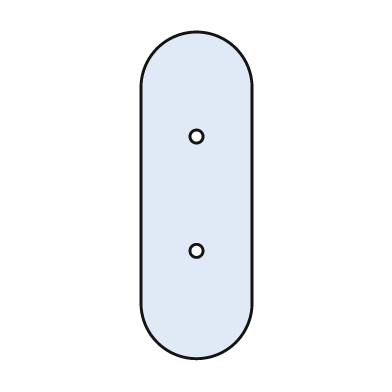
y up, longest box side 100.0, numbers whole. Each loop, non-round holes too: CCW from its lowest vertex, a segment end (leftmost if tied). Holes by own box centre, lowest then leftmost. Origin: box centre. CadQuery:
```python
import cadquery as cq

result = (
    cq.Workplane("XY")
    .moveTo(-17.0, -33.0)
    .threePointArc((0.0, -50.0), (17.0, -33.0))
    .lineTo(17.0, 33.0)
    .threePointArc((0.0, 50.0), (-17.0, 33.0))
    .close()
    .moveTo(0.0, -17.0)
    .circle(2.0)
    .moveTo(0.0, 18.0)
    .circle(2.0)
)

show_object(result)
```